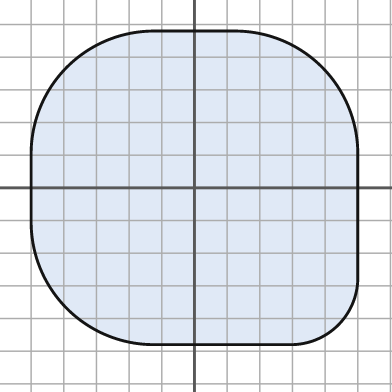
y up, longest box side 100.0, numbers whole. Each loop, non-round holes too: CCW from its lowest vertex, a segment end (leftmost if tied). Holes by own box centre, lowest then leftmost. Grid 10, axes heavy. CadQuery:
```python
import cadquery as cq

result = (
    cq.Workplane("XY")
    .moveTo(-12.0, -48.0)
    .lineTo(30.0, -48.0)
    .threePointArc((44.0, -42.0), (50.0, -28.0))
    .lineTo(50.0, 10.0)
    .threePointArc((39.0, 37.0), (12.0, 48.0))
    .lineTo(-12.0, 48.0)
    .threePointArc((-39.0, 37.0), (-50.0, 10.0))
    .lineTo(-50.0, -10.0)
    .threePointArc((-39.0, -37.0), (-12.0, -48.0))
    .close()
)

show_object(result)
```